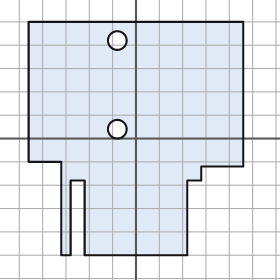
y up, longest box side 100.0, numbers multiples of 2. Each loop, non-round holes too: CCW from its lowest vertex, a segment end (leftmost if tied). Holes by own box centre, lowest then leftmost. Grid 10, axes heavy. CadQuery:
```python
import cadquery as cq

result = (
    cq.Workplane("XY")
    .moveTo(-32.0, -50.0)
    .lineTo(-28.0, -50.0)
    .lineTo(-28.0, -18.0)
    .lineTo(-22.0, -18.0)
    .lineTo(-22.0, -50.0)
    .lineTo(22.0, -50.0)
    .lineTo(22.0, -18.0)
    .lineTo(28.0, -18.0)
    .lineTo(28.0, -12.0)
    .lineTo(46.0, -12.0)
    .lineTo(46.0, 50.0)
    .lineTo(-46.0, 50.0)
    .lineTo(-46.0, -10.0)
    .lineTo(-32.0, -10.0)
    .close()
    .moveTo(-8.0, 4.0)
    .circle(4.0)
    .moveTo(-8.0, 42.0)
    .circle(4.0)
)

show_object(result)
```